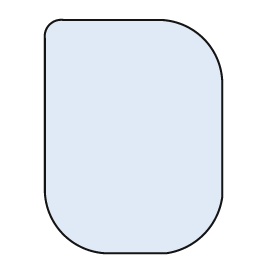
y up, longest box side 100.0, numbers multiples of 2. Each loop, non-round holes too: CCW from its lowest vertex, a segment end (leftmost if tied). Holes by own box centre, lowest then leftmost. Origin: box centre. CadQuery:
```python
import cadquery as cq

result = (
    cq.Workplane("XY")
    .moveTo(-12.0, -50.0)
    .lineTo(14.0, -50.0)
    .threePointArc((30.0, -42.0), (38.0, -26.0))
    .lineTo(38.0, 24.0)
    .threePointArc((30.0, 42.0), (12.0, 50.0))
    .lineTo(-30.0, 50.0)
    .threePointArc((-36.0, 48.0), (-38.0, 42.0))
    .lineTo(-38.0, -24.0)
    .threePointArc((-30.0, -42.0), (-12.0, -50.0))
    .close()
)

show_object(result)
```